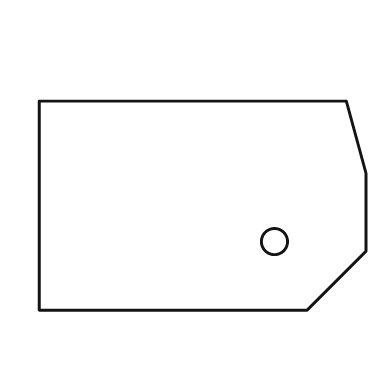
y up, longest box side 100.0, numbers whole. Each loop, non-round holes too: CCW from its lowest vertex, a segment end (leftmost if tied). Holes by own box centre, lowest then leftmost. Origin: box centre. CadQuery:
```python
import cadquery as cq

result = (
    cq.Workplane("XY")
    .moveTo(-50.0, -32.0)
    .lineTo(32.0, -32.0)
    .lineTo(50.0, -14.0)
    .lineTo(50.0, 10.0)
    .lineTo(44.0, 32.0)
    .lineTo(-50.0, 32.0)
    .close()
    .moveTo(22.0, -11.0)
    .circle(4.0)
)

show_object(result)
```